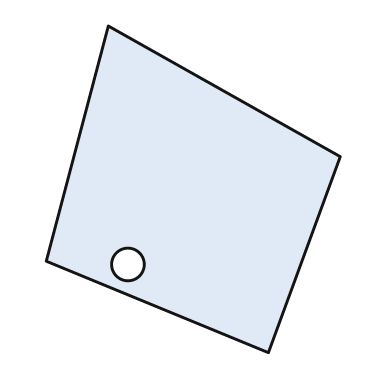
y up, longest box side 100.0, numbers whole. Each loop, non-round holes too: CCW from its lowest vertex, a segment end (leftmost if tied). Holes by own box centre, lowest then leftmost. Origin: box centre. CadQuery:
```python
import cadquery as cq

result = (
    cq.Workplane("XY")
    .moveTo(23.0, -50.0)
    .lineTo(45.0, 10.0)
    .lineTo(-26.0, 50.0)
    .lineTo(-45.0, -22.0)
    .close()
    .moveTo(-20.0, -23.0)
    .circle(5.0)
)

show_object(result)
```